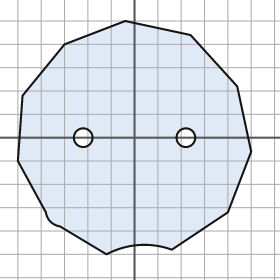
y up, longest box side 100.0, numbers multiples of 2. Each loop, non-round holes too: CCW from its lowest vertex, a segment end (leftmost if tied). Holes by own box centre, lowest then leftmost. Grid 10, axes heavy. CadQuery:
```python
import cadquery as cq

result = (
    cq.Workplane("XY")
    .moveTo(-12.0, -50.0)
    .threePointArc((2.0, -46.0), (16.0, -48.0))
    .lineTo(40.0, -32.0)
    .lineTo(50.0, -6.0)
    .lineTo(44.0, 22.0)
    .lineTo(24.0, 44.0)
    .lineTo(-4.0, 50.0)
    .lineTo(-30.0, 40.0)
    .lineTo(-48.0, 18.0)
    .lineTo(-50.0, -10.0)
    .lineTo(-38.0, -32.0)
    .threePointArc((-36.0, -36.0), (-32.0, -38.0))
    .close()
    .moveTo(-22.0, 0.0)
    .circle(4.0)
    .moveTo(22.0, 0.0)
    .circle(4.0)
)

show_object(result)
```